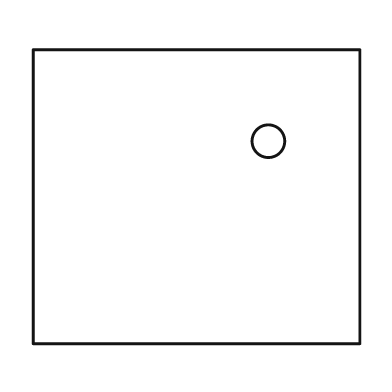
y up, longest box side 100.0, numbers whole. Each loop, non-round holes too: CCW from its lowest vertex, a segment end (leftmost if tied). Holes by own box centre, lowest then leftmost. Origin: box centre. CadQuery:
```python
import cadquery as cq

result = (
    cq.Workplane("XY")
    .moveTo(-50.0, -45.0)
    .lineTo(50.0, -45.0)
    .lineTo(50.0, 45.0)
    .lineTo(-50.0, 45.0)
    .close()
    .moveTo(22.0, 17.0)
    .circle(5.0)
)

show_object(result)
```